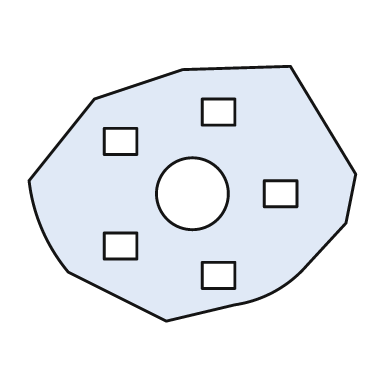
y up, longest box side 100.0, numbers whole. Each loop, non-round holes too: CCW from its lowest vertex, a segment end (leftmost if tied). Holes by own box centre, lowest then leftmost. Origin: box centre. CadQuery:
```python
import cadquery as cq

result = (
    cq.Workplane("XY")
    .moveTo(-8.0, -39.0)
    .lineTo(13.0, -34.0)
    .threePointArc((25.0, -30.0), (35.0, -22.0))
    .lineTo(47.0, -9.0)
    .lineTo(50.0, 6.0)
    .lineTo(30.0, 39.0)
    .lineTo(-3.0, 38.0)
    .lineTo(-30.0, 29.0)
    .lineTo(-50.0, 4.0)
    .threePointArc((-46.0, -11.0), (-38.0, -24.0))
    .close()
    .moveTo(3.0, -29.0)
    .lineTo(13.0, -29.0)
    .lineTo(13.0, -21.0)
    .lineTo(3.0, -21.0)
    .close()
    .moveTo(-27.0, -20.0)
    .lineTo(-17.0, -20.0)
    .lineTo(-17.0, -12.0)
    .lineTo(-27.0, -12.0)
    .close()
    .moveTo(0.0, 0.0)
    .circle(11.0)
    .moveTo(22.0, -4.0)
    .lineTo(32.0, -4.0)
    .lineTo(32.0, 4.0)
    .lineTo(22.0, 4.0)
    .close()
    .moveTo(-27.0, 12.0)
    .lineTo(-17.0, 12.0)
    .lineTo(-17.0, 20.0)
    .lineTo(-27.0, 20.0)
    .close()
    .moveTo(3.0, 21.0)
    .lineTo(13.0, 21.0)
    .lineTo(13.0, 29.0)
    .lineTo(3.0, 29.0)
    .close()
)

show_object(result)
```